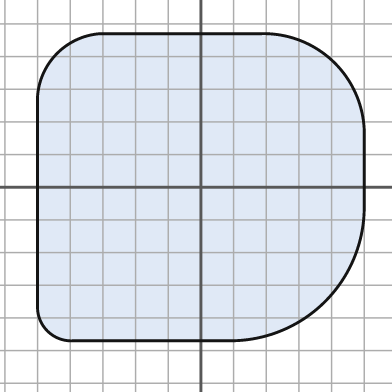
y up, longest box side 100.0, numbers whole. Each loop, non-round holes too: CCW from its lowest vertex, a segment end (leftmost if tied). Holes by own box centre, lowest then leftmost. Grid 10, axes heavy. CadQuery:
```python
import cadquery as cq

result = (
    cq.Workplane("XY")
    .moveTo(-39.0, -47.0)
    .lineTo(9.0, -47.0)
    .threePointArc((38.0, -35.0), (50.0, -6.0))
    .lineTo(50.0, 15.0)
    .threePointArc((41.0, 38.0), (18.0, 47.0))
    .lineTo(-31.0, 47.0)
    .threePointArc((-44.0, 41.0), (-50.0, 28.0))
    .lineTo(-50.0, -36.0)
    .threePointArc((-47.0, -44.0), (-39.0, -47.0))
    .close()
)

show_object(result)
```